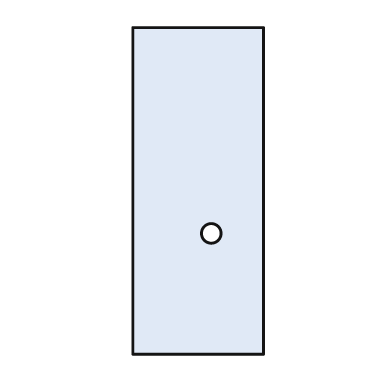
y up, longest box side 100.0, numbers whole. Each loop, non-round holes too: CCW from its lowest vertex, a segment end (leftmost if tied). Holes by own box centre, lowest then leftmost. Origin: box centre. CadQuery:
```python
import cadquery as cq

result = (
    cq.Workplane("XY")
    .moveTo(-20.0, -50.0)
    .lineTo(20.0, -50.0)
    .lineTo(20.0, 50.0)
    .lineTo(-20.0, 50.0)
    .close()
    .moveTo(4.0, -13.0)
    .circle(3.0)
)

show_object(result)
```